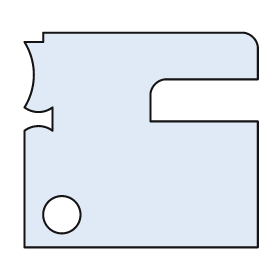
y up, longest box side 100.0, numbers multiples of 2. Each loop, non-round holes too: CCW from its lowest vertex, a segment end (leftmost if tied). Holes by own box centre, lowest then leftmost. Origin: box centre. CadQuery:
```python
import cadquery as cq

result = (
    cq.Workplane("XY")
    .moveTo(-50.0, -46.0)
    .lineTo(50.0, -46.0)
    .lineTo(50.0, 8.0)
    .lineTo(4.0, 8.0)
    .lineTo(4.0, 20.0)
    .threePointArc((6.0, 24.0), (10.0, 26.0))
    .lineTo(50.0, 26.0)
    .lineTo(50.0, 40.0)
    .threePointArc((48.0, 44.0), (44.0, 46.0))
    .lineTo(-42.0, 46.0)
    .lineTo(-42.0, 42.0)
    .lineTo(-50.0, 42.0)
    .threePointArc((-46.0, 28.0), (-50.0, 14.0))
    .threePointArc((-44.0, 12.0), (-38.0, 14.0))
    .lineTo(-38.0, 4.0)
    .threePointArc((-44.0, 6.0), (-50.0, 4.0))
    .close()
    .moveTo(-34.0, -32.0)
    .circle(8.0)
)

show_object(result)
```